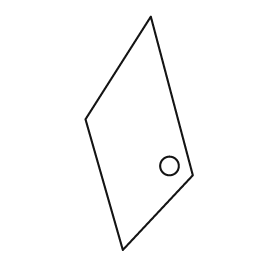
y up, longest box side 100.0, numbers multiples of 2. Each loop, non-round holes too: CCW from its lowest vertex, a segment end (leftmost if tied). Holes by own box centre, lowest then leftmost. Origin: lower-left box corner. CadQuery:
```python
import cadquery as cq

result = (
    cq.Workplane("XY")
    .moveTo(16.0, 0.0)
    .lineTo(46.0, 32.0)
    .lineTo(28.0, 100.0)
    .lineTo(0.0, 56.0)
    .close()
    .moveTo(36.0, 36.0)
    .circle(4.0)
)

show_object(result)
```